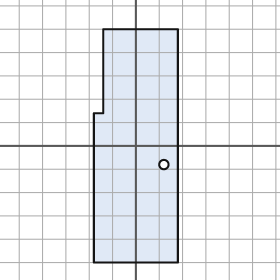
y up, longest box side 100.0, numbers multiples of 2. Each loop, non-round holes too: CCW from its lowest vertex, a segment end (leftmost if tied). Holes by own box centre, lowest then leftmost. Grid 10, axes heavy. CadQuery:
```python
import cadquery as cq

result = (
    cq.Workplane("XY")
    .moveTo(-18.0, -50.0)
    .lineTo(18.0, -50.0)
    .lineTo(18.0, 50.0)
    .lineTo(-14.0, 50.0)
    .lineTo(-14.0, 14.0)
    .lineTo(-18.0, 14.0)
    .close()
    .moveTo(12.0, -8.0)
    .circle(2.0)
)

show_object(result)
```